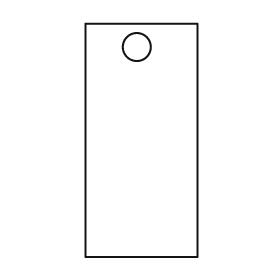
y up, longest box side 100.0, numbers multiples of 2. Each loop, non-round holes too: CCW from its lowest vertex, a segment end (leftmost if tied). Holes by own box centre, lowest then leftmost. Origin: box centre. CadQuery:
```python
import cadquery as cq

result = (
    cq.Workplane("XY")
    .moveTo(-24.0, -50.0)
    .lineTo(24.0, -50.0)
    .lineTo(24.0, 50.0)
    .lineTo(-24.0, 50.0)
    .close()
    .moveTo(-2.0, 40.0)
    .circle(6.0)
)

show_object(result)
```